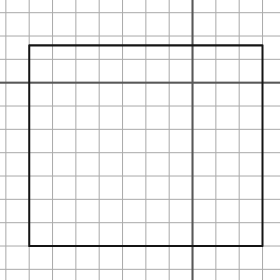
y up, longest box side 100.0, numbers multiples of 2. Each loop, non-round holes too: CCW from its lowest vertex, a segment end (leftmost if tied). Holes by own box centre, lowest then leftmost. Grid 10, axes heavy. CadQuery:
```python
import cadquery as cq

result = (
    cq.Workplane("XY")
    .moveTo(-70.0, -70.0)
    .lineTo(30.0, -70.0)
    .lineTo(30.0, 16.0)
    .lineTo(-70.0, 16.0)
    .close()
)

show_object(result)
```